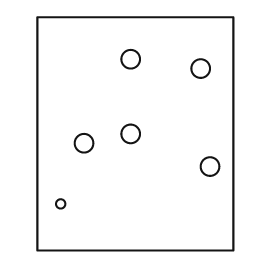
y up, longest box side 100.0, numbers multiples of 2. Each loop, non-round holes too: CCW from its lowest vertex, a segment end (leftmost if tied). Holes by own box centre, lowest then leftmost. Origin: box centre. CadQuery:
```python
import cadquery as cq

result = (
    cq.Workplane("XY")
    .moveTo(-42.0, -50.0)
    .lineTo(42.0, -50.0)
    .lineTo(42.0, 50.0)
    .lineTo(-42.0, 50.0)
    .close()
    .moveTo(-32.0, -30.0)
    .circle(2.0)
    .moveTo(32.0, -14.0)
    .circle(4.0)
    .moveTo(-22.0, -4.0)
    .circle(4.0)
    .moveTo(-2.0, 0.0)
    .circle(4.0)
    .moveTo(28.0, 28.0)
    .circle(4.0)
    .moveTo(-2.0, 32.0)
    .circle(4.0)
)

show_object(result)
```